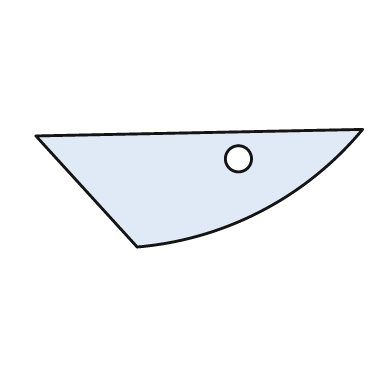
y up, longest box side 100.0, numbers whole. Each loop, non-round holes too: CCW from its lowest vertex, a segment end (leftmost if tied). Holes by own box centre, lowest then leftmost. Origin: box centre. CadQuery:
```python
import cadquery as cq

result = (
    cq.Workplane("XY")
    .moveTo(-19.0, -18.0)
    .threePointArc((19.0, -7.0), (50.0, 18.0))
    .lineTo(-50.0, 16.0)
    .close()
    .moveTo(12.0, 9.0)
    .circle(4.0)
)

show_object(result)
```